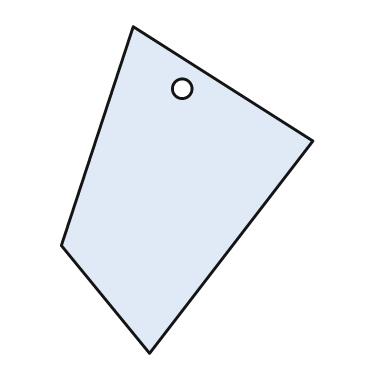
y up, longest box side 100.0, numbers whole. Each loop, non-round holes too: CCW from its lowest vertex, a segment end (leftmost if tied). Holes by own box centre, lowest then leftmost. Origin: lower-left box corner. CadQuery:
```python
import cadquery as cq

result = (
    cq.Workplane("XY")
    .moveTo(27.0, 0.0)
    .lineTo(77.0, 65.0)
    .lineTo(22.0, 100.0)
    .lineTo(0.0, 33.0)
    .close()
    .moveTo(37.0, 81.0)
    .circle(3.0)
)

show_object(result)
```